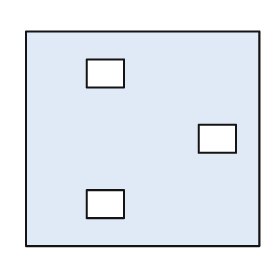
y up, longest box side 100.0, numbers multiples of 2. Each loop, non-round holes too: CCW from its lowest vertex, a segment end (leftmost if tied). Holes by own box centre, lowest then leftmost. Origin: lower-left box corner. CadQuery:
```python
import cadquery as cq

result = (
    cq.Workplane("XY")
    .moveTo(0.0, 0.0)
    .lineTo(100.0, 0.0)
    .lineTo(100.0, 92.0)
    .lineTo(0.0, 92.0)
    .close()
    .moveTo(26.0, 12.0)
    .lineTo(42.0, 12.0)
    .lineTo(42.0, 24.0)
    .lineTo(26.0, 24.0)
    .close()
    .moveTo(74.0, 40.0)
    .lineTo(90.0, 40.0)
    .lineTo(90.0, 52.0)
    .lineTo(74.0, 52.0)
    .close()
    .moveTo(26.0, 68.0)
    .lineTo(42.0, 68.0)
    .lineTo(42.0, 80.0)
    .lineTo(26.0, 80.0)
    .close()
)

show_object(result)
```